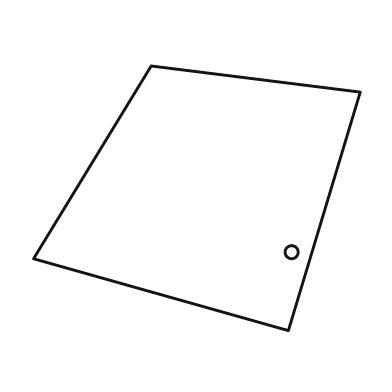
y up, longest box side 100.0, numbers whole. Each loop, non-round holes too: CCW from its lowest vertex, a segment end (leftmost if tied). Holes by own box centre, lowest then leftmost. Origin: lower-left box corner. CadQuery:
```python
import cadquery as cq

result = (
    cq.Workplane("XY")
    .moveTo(78.0, 0.0)
    .lineTo(100.0, 73.0)
    .lineTo(36.0, 81.0)
    .lineTo(0.0, 22.0)
    .close()
    .moveTo(79.0, 24.0)
    .circle(2.0)
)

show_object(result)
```